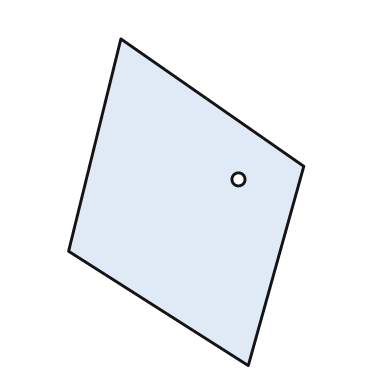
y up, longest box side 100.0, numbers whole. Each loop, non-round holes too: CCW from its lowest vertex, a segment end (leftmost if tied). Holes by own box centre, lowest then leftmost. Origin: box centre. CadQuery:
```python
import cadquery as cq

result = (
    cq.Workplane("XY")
    .moveTo(19.0, -50.0)
    .lineTo(36.0, 11.0)
    .lineTo(-20.0, 50.0)
    .lineTo(-36.0, -15.0)
    .close()
    .moveTo(16.0, 7.0)
    .circle(2.0)
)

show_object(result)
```